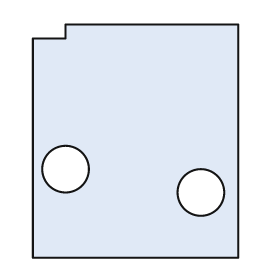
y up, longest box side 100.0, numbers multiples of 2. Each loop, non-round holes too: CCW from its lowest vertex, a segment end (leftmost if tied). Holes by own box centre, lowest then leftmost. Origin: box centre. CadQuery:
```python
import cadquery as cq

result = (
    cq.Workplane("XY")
    .moveTo(-44.0, -50.0)
    .lineTo(44.0, -50.0)
    .lineTo(44.0, 50.0)
    .lineTo(-30.0, 50.0)
    .lineTo(-30.0, 44.0)
    .lineTo(-44.0, 44.0)
    .close()
    .moveTo(28.0, -22.0)
    .circle(10.0)
    .moveTo(-30.0, -12.0)
    .circle(10.0)
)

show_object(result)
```